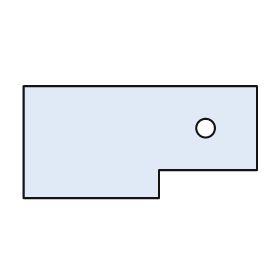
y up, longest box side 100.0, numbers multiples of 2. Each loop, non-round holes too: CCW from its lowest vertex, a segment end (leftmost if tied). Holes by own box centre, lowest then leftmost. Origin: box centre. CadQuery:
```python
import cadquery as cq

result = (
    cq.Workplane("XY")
    .moveTo(-50.0, -24.0)
    .lineTo(8.0, -24.0)
    .lineTo(8.0, -12.0)
    .lineTo(50.0, -12.0)
    .lineTo(50.0, 24.0)
    .lineTo(-50.0, 24.0)
    .close()
    .moveTo(28.0, 6.0)
    .circle(4.0)
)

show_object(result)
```